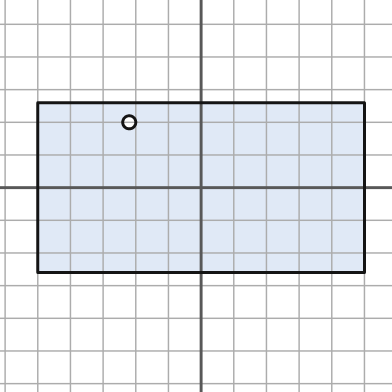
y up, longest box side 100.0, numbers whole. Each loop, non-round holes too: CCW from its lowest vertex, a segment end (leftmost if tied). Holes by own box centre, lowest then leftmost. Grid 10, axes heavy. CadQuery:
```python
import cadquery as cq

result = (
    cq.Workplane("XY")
    .moveTo(-50.0, -26.0)
    .lineTo(50.0, -26.0)
    .lineTo(50.0, 26.0)
    .lineTo(-50.0, 26.0)
    .close()
    .moveTo(-22.0, 20.0)
    .circle(2.0)
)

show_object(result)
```